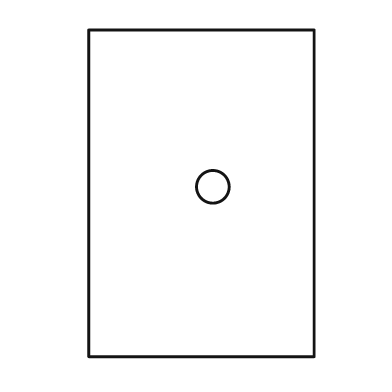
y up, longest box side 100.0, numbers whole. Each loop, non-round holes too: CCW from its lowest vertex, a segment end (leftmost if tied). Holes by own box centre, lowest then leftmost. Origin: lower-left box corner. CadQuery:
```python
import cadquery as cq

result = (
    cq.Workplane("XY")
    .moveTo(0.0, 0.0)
    .lineTo(69.0, 0.0)
    .lineTo(69.0, 100.0)
    .lineTo(0.0, 100.0)
    .close()
    .moveTo(38.0, 52.0)
    .circle(5.0)
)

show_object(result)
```